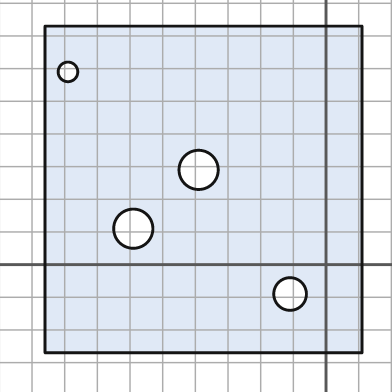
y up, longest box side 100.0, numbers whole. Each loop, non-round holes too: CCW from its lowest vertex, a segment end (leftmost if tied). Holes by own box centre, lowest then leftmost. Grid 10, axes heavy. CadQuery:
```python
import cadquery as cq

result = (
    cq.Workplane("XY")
    .moveTo(-86.0, -27.0)
    .lineTo(11.0, -27.0)
    .lineTo(11.0, 73.0)
    .lineTo(-86.0, 73.0)
    .close()
    .moveTo(-11.0, -9.0)
    .circle(5.0)
    .moveTo(-59.0, 11.0)
    .circle(6.0)
    .moveTo(-39.0, 29.0)
    .circle(6.0)
    .moveTo(-79.0, 59.0)
    .circle(3.0)
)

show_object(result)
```